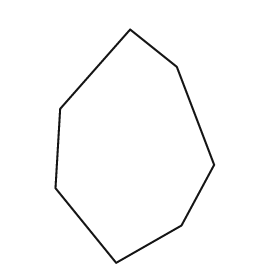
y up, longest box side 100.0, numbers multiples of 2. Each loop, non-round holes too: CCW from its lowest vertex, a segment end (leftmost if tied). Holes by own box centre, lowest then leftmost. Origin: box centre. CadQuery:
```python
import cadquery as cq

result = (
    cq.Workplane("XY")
    .moveTo(-8.0, -50.0)
    .lineTo(20.0, -34.0)
    .lineTo(34.0, -8.0)
    .lineTo(18.0, 34.0)
    .lineTo(-2.0, 50.0)
    .lineTo(-32.0, 16.0)
    .lineTo(-34.0, -18.0)
    .close()
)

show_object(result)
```